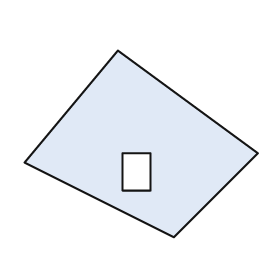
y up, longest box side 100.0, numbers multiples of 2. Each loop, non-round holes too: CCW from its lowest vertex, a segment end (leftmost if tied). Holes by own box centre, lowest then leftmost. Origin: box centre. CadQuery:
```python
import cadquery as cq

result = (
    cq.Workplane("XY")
    .moveTo(14.0, -40.0)
    .lineTo(50.0, -4.0)
    .lineTo(-10.0, 40.0)
    .lineTo(-50.0, -8.0)
    .close()
    .moveTo(-8.0, -20.0)
    .lineTo(4.0, -20.0)
    .lineTo(4.0, -4.0)
    .lineTo(-8.0, -4.0)
    .close()
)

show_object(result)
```